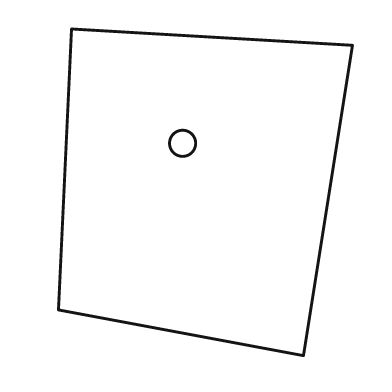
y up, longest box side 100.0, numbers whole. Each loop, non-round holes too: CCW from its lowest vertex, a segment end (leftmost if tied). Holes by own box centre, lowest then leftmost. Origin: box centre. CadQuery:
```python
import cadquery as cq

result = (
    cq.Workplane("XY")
    .moveTo(30.0, -50.0)
    .lineTo(45.0, 45.0)
    .lineTo(-41.0, 50.0)
    .lineTo(-45.0, -36.0)
    .close()
    .moveTo(-7.0, 15.0)
    .circle(4.0)
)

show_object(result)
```